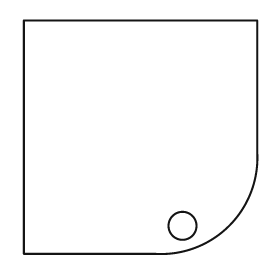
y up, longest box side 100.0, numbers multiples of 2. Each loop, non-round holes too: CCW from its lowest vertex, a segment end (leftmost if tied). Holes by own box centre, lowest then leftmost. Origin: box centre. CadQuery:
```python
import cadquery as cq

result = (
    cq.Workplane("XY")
    .moveTo(-50.0, -50.0)
    .lineTo(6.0, -50.0)
    .threePointArc((38.0, -38.0), (50.0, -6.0))
    .lineTo(50.0, 50.0)
    .lineTo(-50.0, 50.0)
    .close()
    .moveTo(18.0, -38.0)
    .circle(6.0)
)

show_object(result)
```